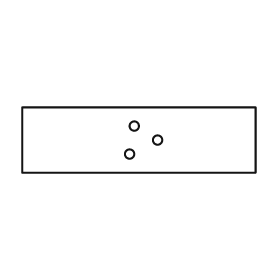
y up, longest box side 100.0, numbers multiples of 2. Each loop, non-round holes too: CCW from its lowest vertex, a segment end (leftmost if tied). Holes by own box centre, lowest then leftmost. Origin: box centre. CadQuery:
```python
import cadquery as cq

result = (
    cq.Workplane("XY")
    .moveTo(-50.0, -14.0)
    .lineTo(50.0, -14.0)
    .lineTo(50.0, 14.0)
    .lineTo(-50.0, 14.0)
    .close()
    .moveTo(-4.0, -6.0)
    .circle(2.0)
    .moveTo(8.0, 0.0)
    .circle(2.0)
    .moveTo(-2.0, 6.0)
    .circle(2.0)
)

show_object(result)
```